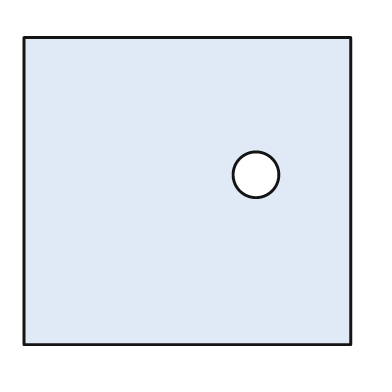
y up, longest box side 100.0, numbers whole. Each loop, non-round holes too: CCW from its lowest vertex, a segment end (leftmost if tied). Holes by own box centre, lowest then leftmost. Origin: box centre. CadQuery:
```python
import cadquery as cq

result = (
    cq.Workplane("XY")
    .moveTo(-50.0, -47.0)
    .lineTo(50.0, -47.0)
    .lineTo(50.0, 47.0)
    .lineTo(-50.0, 47.0)
    .close()
    .moveTo(21.0, 5.0)
    .circle(7.0)
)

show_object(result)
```